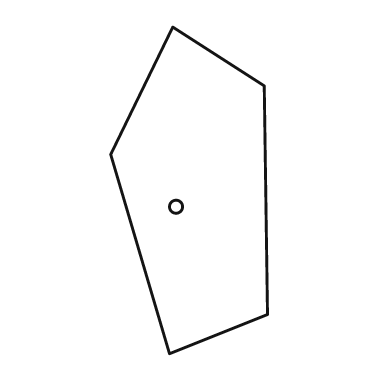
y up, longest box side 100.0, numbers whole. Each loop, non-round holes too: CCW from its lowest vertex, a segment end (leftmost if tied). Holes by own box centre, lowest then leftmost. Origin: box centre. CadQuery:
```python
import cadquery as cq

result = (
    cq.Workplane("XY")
    .moveTo(-6.0, -50.0)
    .lineTo(24.0, -38.0)
    .lineTo(23.0, 32.0)
    .lineTo(-5.0, 50.0)
    .lineTo(-24.0, 11.0)
    .close()
    .moveTo(-4.0, -5.0)
    .circle(2.0)
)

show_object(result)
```